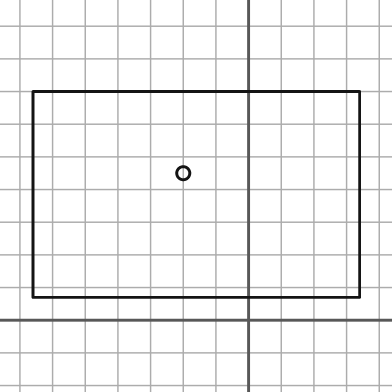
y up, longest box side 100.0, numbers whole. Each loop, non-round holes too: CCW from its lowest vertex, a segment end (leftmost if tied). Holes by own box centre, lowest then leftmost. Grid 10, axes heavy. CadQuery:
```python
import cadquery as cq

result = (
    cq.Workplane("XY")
    .moveTo(-66.0, 7.0)
    .lineTo(34.0, 7.0)
    .lineTo(34.0, 70.0)
    .lineTo(-66.0, 70.0)
    .close()
    .moveTo(-20.0, 45.0)
    .circle(2.0)
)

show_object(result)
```